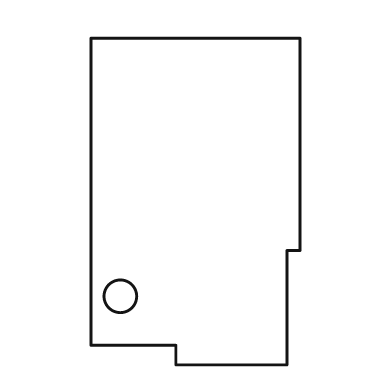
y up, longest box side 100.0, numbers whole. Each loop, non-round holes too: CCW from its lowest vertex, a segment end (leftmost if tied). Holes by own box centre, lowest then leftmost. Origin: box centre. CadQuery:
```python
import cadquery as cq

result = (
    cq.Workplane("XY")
    .moveTo(-6.0, -50.0)
    .lineTo(28.0, -50.0)
    .lineTo(28.0, -15.0)
    .lineTo(32.0, -15.0)
    .lineTo(32.0, 50.0)
    .lineTo(-32.0, 50.0)
    .lineTo(-32.0, -44.0)
    .lineTo(-6.0, -44.0)
    .close()
    .moveTo(-23.0, -29.0)
    .circle(5.0)
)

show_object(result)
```